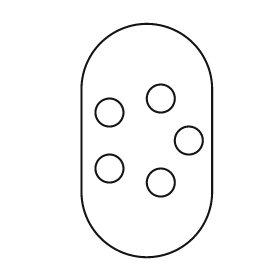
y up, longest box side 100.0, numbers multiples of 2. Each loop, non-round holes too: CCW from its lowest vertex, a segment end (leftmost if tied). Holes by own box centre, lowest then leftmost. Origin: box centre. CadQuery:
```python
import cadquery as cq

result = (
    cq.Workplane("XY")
    .moveTo(-28.0, -22.0)
    .threePointArc((0.0, -50.0), (28.0, -22.0))
    .lineTo(28.0, 22.0)
    .threePointArc((0.0, 50.0), (-28.0, 22.0))
    .close()
    .moveTo(6.0, -18.0)
    .circle(6.0)
    .moveTo(-16.0, -12.0)
    .circle(6.0)
    .moveTo(18.0, 0.0)
    .circle(6.0)
    .moveTo(-16.0, 12.0)
    .circle(6.0)
    .moveTo(6.0, 18.0)
    .circle(6.0)
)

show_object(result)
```